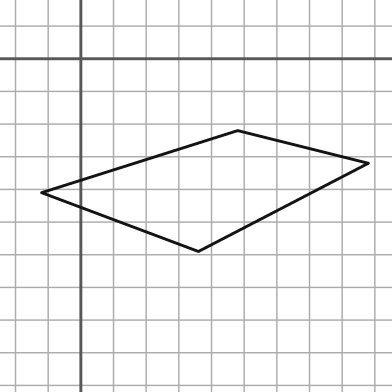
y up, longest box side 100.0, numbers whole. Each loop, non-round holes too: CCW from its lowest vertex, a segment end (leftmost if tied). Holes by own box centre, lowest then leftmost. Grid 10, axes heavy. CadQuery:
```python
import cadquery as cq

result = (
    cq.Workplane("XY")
    .moveTo(36.0, -59.0)
    .lineTo(88.0, -32.0)
    .lineTo(48.0, -22.0)
    .lineTo(-12.0, -41.0)
    .close()
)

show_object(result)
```